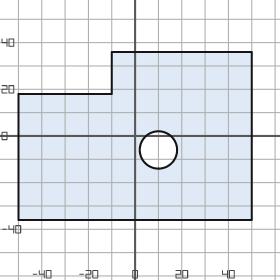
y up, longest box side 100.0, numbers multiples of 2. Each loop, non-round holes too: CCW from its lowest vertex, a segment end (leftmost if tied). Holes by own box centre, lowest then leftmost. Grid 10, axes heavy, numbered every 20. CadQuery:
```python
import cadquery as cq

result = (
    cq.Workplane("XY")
    .moveTo(-50.0, -36.0)
    .lineTo(50.0, -36.0)
    .lineTo(50.0, 36.0)
    .lineTo(-10.0, 36.0)
    .lineTo(-10.0, 18.0)
    .lineTo(-50.0, 18.0)
    .close()
    .moveTo(10.0, -6.0)
    .circle(8.0)
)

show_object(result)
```